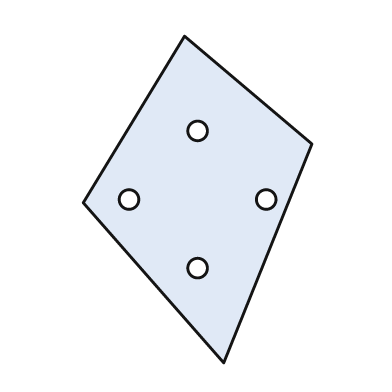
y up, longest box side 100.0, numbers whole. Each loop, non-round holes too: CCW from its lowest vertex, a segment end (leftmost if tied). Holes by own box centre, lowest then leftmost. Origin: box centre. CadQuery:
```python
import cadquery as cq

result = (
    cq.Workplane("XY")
    .moveTo(8.0, -50.0)
    .lineTo(35.0, 17.0)
    .lineTo(-4.0, 50.0)
    .lineTo(-35.0, -1.0)
    .close()
    .moveTo(0.0, -21.0)
    .circle(3.0)
    .moveTo(-21.0, 0.0)
    .circle(3.0)
    .moveTo(21.0, 0.0)
    .circle(3.0)
    .moveTo(0.0, 21.0)
    .circle(3.0)
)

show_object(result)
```